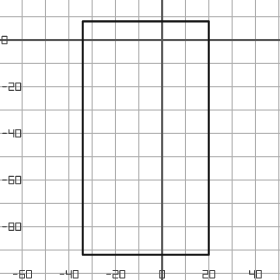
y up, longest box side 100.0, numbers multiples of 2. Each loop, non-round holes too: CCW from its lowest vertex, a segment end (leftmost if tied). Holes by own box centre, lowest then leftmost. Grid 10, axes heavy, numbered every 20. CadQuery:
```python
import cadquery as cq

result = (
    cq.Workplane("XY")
    .moveTo(-34.0, -92.0)
    .lineTo(20.0, -92.0)
    .lineTo(20.0, 8.0)
    .lineTo(-34.0, 8.0)
    .close()
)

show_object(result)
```